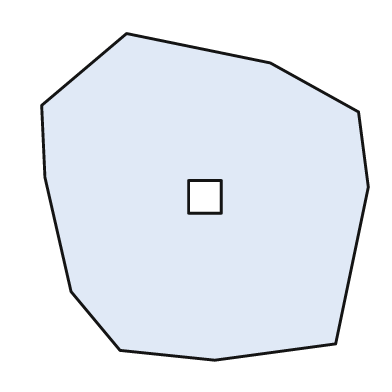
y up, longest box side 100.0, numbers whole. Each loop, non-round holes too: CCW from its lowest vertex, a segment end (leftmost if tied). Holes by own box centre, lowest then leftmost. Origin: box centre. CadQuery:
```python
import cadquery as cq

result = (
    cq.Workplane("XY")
    .moveTo(3.0, -50.0)
    .lineTo(40.0, -45.0)
    .lineTo(50.0, 3.0)
    .lineTo(47.0, 26.0)
    .lineTo(20.0, 41.0)
    .lineTo(-24.0, 50.0)
    .lineTo(-50.0, 28.0)
    .lineTo(-49.0, 6.0)
    .lineTo(-41.0, -29.0)
    .lineTo(-26.0, -47.0)
    .close()
    .moveTo(-5.0, -5.0)
    .lineTo(5.0, -5.0)
    .lineTo(5.0, 5.0)
    .lineTo(-5.0, 5.0)
    .close()
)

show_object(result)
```